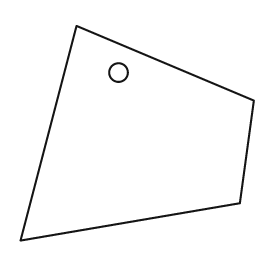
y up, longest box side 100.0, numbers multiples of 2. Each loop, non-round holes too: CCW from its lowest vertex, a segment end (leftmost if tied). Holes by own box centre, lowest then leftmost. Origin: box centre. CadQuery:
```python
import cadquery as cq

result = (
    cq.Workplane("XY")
    .moveTo(-50.0, -46.0)
    .lineTo(44.0, -30.0)
    .lineTo(50.0, 14.0)
    .lineTo(-26.0, 46.0)
    .close()
    .moveTo(-8.0, 26.0)
    .circle(4.0)
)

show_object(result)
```